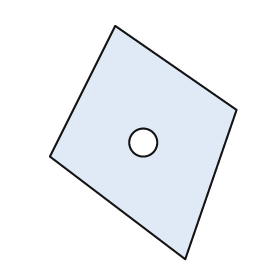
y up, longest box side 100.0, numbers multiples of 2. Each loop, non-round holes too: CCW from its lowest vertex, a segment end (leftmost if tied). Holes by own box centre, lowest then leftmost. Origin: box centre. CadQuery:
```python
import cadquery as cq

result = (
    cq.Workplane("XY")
    .moveTo(18.0, -50.0)
    .lineTo(40.0, 14.0)
    .lineTo(-12.0, 50.0)
    .lineTo(-40.0, -6.0)
    .close()
    .moveTo(0.0, 0.0)
    .circle(6.0)
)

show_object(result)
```